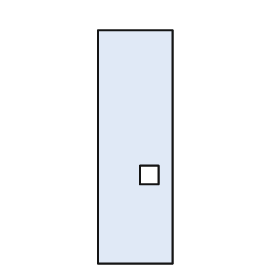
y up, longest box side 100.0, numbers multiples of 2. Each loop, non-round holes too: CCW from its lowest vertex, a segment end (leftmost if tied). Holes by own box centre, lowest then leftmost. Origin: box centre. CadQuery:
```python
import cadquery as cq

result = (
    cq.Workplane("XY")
    .moveTo(-16.0, -50.0)
    .lineTo(16.0, -50.0)
    .lineTo(16.0, 50.0)
    .lineTo(-16.0, 50.0)
    .close()
    .moveTo(2.0, -16.0)
    .lineTo(10.0, -16.0)
    .lineTo(10.0, -8.0)
    .lineTo(2.0, -8.0)
    .close()
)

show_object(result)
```